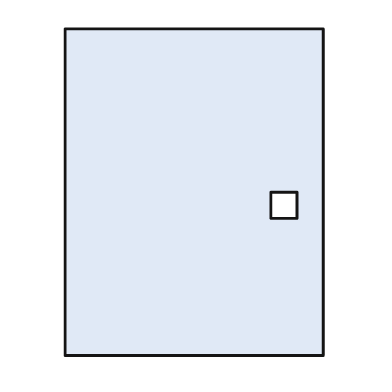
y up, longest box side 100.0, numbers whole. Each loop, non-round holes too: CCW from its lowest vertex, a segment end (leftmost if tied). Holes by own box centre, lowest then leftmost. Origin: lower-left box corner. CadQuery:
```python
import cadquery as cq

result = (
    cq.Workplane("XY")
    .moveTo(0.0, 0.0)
    .lineTo(79.0, 0.0)
    .lineTo(79.0, 100.0)
    .lineTo(0.0, 100.0)
    .close()
    .moveTo(63.0, 42.0)
    .lineTo(71.0, 42.0)
    .lineTo(71.0, 50.0)
    .lineTo(63.0, 50.0)
    .close()
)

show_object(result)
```